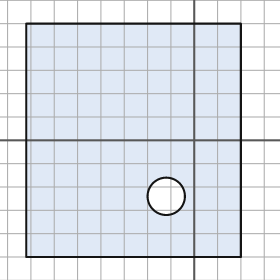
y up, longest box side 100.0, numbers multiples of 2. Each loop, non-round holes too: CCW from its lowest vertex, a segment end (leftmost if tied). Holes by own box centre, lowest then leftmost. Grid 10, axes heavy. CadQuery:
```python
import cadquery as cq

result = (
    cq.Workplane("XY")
    .moveTo(-72.0, -50.0)
    .lineTo(20.0, -50.0)
    .lineTo(20.0, 50.0)
    .lineTo(-72.0, 50.0)
    .close()
    .moveTo(-12.0, -24.0)
    .circle(8.0)
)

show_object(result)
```